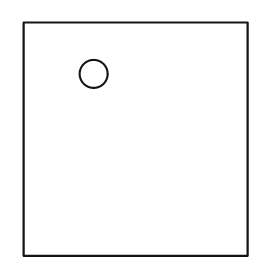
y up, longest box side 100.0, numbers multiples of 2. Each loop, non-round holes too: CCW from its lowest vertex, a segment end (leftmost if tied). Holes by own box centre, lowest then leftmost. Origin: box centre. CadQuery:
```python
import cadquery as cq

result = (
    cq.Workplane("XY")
    .moveTo(-48.0, -50.0)
    .lineTo(48.0, -50.0)
    .lineTo(48.0, 50.0)
    .lineTo(-48.0, 50.0)
    .close()
    .moveTo(-18.0, 28.0)
    .circle(6.0)
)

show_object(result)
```